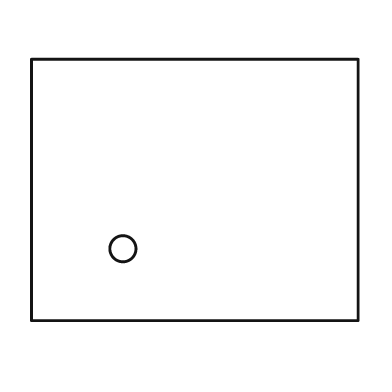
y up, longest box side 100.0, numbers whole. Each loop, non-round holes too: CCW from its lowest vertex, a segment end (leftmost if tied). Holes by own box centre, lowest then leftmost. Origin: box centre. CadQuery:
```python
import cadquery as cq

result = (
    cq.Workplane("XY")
    .moveTo(-50.0, -40.0)
    .lineTo(50.0, -40.0)
    .lineTo(50.0, 40.0)
    .lineTo(-50.0, 40.0)
    .close()
    .moveTo(-22.0, -18.0)
    .circle(4.0)
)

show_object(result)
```